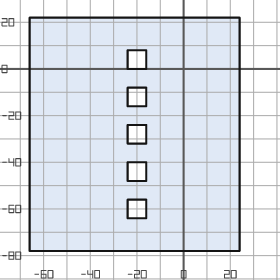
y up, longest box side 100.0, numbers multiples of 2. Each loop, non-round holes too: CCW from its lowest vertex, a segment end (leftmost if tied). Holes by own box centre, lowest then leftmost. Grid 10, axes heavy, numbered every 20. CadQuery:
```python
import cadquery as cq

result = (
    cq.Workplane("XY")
    .moveTo(-66.0, -78.0)
    .lineTo(24.0, -78.0)
    .lineTo(24.0, 22.0)
    .lineTo(-66.0, 22.0)
    .close()
    .moveTo(-24.0, -64.0)
    .lineTo(-16.0, -64.0)
    .lineTo(-16.0, -56.0)
    .lineTo(-24.0, -56.0)
    .close()
    .moveTo(-24.0, -48.0)
    .lineTo(-16.0, -48.0)
    .lineTo(-16.0, -40.0)
    .lineTo(-24.0, -40.0)
    .close()
    .moveTo(-24.0, -32.0)
    .lineTo(-16.0, -32.0)
    .lineTo(-16.0, -24.0)
    .lineTo(-24.0, -24.0)
    .close()
    .moveTo(-24.0, -16.0)
    .lineTo(-16.0, -16.0)
    .lineTo(-16.0, -8.0)
    .lineTo(-24.0, -8.0)
    .close()
    .moveTo(-24.0, 0.0)
    .lineTo(-16.0, 0.0)
    .lineTo(-16.0, 8.0)
    .lineTo(-24.0, 8.0)
    .close()
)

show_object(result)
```